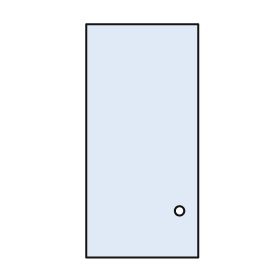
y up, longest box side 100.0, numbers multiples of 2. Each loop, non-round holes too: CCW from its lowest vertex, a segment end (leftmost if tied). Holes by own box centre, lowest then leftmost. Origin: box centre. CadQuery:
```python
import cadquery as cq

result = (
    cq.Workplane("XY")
    .moveTo(-24.0, -50.0)
    .lineTo(24.0, -50.0)
    .lineTo(24.0, 50.0)
    .lineTo(-24.0, 50.0)
    .close()
    .moveTo(16.0, -30.0)
    .circle(2.0)
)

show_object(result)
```